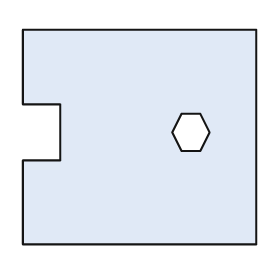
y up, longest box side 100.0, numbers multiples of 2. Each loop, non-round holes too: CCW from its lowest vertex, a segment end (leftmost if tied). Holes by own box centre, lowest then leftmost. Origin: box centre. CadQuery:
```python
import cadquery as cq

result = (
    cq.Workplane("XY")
    .moveTo(-50.0, -46.0)
    .lineTo(50.0, -46.0)
    .lineTo(50.0, 46.0)
    .lineTo(-50.0, 46.0)
    .lineTo(-50.0, 14.0)
    .lineTo(-34.0, 14.0)
    .lineTo(-34.0, -10.0)
    .lineTo(-50.0, -10.0)
    .close()
    .moveTo(18.0, -6.0)
    .lineTo(26.0, -6.0)
    .lineTo(30.0, 2.0)
    .lineTo(26.0, 10.0)
    .lineTo(18.0, 10.0)
    .lineTo(14.0, 2.0)
    .close()
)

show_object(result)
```